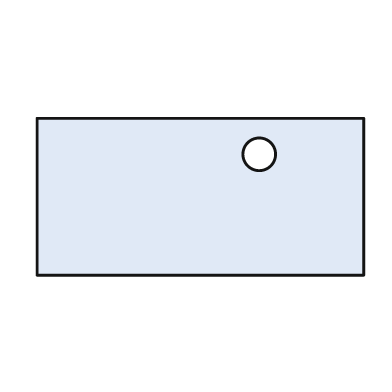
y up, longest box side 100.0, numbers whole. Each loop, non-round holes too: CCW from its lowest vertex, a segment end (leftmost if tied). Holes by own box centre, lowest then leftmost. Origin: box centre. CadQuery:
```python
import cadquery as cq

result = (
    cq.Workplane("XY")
    .moveTo(-50.0, -24.0)
    .lineTo(50.0, -24.0)
    .lineTo(50.0, 24.0)
    .lineTo(-50.0, 24.0)
    .close()
    .moveTo(18.0, 13.0)
    .circle(5.0)
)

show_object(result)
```